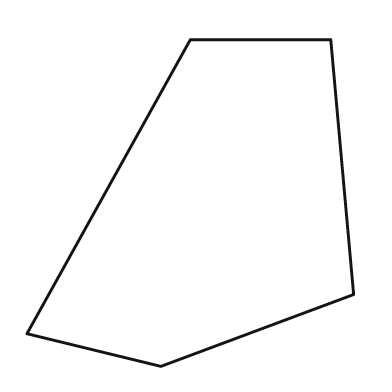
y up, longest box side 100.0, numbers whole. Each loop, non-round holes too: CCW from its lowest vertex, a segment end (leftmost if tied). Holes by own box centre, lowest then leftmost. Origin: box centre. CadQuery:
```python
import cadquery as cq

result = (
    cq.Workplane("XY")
    .moveTo(-9.0, -50.0)
    .lineTo(50.0, -28.0)
    .lineTo(43.0, 50.0)
    .lineTo(0.0, 50.0)
    .lineTo(-50.0, -40.0)
    .close()
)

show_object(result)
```